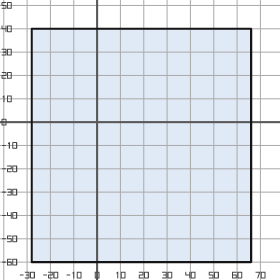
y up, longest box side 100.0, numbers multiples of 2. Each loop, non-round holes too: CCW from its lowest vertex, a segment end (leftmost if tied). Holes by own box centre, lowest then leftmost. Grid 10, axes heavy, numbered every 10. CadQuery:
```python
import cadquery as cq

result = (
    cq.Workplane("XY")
    .moveTo(-28.0, -60.0)
    .lineTo(66.0, -60.0)
    .lineTo(66.0, 40.0)
    .lineTo(-28.0, 40.0)
    .close()
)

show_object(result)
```